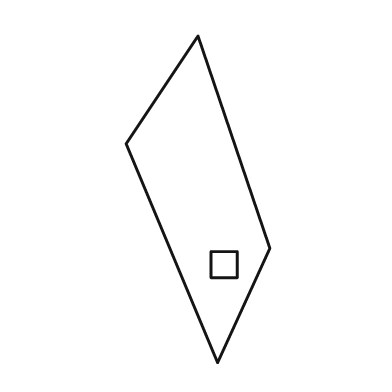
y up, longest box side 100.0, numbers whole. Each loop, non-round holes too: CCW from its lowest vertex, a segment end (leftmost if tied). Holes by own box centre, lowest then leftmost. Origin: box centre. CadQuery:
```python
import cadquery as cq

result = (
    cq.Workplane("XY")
    .moveTo(6.0, -50.0)
    .lineTo(22.0, -15.0)
    .lineTo(0.0, 50.0)
    .lineTo(-22.0, 17.0)
    .close()
    .moveTo(4.0, -24.0)
    .lineTo(12.0, -24.0)
    .lineTo(12.0, -16.0)
    .lineTo(4.0, -16.0)
    .close()
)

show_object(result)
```